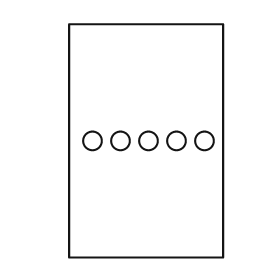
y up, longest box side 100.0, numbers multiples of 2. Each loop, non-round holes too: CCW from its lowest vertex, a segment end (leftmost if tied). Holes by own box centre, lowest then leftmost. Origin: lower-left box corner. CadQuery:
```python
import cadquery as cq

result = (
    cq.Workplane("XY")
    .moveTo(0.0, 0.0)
    .lineTo(66.0, 0.0)
    .lineTo(66.0, 100.0)
    .lineTo(0.0, 100.0)
    .close()
    .moveTo(10.0, 50.0)
    .circle(4.0)
    .moveTo(22.0, 50.0)
    .circle(4.0)
    .moveTo(34.0, 50.0)
    .circle(4.0)
    .moveTo(46.0, 50.0)
    .circle(4.0)
    .moveTo(58.0, 50.0)
    .circle(4.0)
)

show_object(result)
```